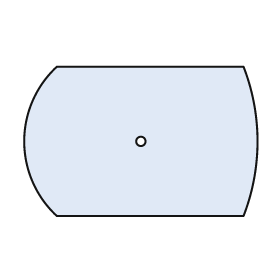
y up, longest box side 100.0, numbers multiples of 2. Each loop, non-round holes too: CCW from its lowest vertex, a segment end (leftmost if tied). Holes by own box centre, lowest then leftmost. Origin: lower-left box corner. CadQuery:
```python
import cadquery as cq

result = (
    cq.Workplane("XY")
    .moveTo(14.0, 0.0)
    .lineTo(94.0, 0.0)
    .threePointArc((100.0, 32.0), (94.0, 64.0))
    .lineTo(14.0, 64.0)
    .threePointArc((0.0, 32.0), (14.0, 0.0))
    .close()
    .moveTo(50.0, 32.0)
    .circle(2.0)
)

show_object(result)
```